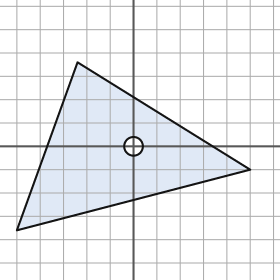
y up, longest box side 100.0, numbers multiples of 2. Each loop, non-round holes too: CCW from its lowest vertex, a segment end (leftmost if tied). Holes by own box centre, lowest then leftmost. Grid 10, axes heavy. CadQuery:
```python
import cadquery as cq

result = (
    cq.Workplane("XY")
    .moveTo(-50.0, -36.0)
    .lineTo(50.0, -10.0)
    .lineTo(-24.0, 36.0)
    .close()
    .moveTo(0.0, 0.0)
    .circle(4.0)
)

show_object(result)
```